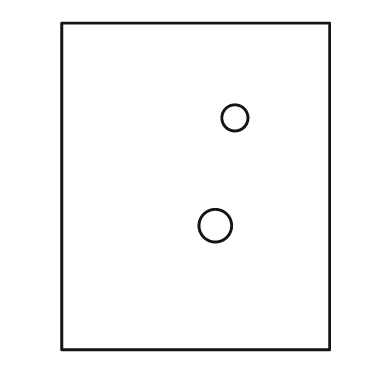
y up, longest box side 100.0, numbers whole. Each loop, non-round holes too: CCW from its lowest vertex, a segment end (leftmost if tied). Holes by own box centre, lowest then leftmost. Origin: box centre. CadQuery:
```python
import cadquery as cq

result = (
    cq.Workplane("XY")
    .moveTo(-41.0, -50.0)
    .lineTo(41.0, -50.0)
    .lineTo(41.0, 50.0)
    .lineTo(-41.0, 50.0)
    .close()
    .moveTo(6.0, -12.0)
    .circle(5.0)
    .moveTo(12.0, 21.0)
    .circle(4.0)
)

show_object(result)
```